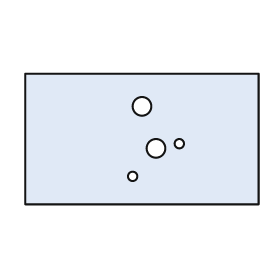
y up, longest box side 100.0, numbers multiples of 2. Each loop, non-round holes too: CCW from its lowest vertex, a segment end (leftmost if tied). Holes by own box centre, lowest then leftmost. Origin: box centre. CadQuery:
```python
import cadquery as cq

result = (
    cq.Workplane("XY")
    .moveTo(-50.0, -28.0)
    .lineTo(50.0, -28.0)
    .lineTo(50.0, 28.0)
    .lineTo(-50.0, 28.0)
    .close()
    .moveTo(-4.0, -16.0)
    .circle(2.0)
    .moveTo(6.0, -4.0)
    .circle(4.0)
    .moveTo(16.0, -2.0)
    .circle(2.0)
    .moveTo(0.0, 14.0)
    .circle(4.0)
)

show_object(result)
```